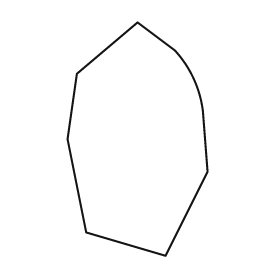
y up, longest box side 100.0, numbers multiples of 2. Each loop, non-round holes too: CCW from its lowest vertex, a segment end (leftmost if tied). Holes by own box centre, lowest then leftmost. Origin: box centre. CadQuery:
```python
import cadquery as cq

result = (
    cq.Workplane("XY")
    .moveTo(12.0, -50.0)
    .lineTo(30.0, -14.0)
    .lineTo(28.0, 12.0)
    .threePointArc((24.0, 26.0), (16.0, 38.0))
    .lineTo(0.0, 50.0)
    .lineTo(-26.0, 28.0)
    .lineTo(-30.0, 0.0)
    .lineTo(-22.0, -40.0)
    .close()
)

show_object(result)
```